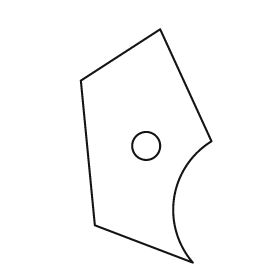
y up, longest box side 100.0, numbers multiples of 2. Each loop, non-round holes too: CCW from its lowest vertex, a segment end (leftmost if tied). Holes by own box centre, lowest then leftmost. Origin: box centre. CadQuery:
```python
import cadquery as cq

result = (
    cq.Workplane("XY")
    .moveTo(20.0, -50.0)
    .threePointArc((12.0, -22.0), (28.0, 2.0))
    .lineTo(6.0, 50.0)
    .lineTo(-28.0, 28.0)
    .lineTo(-22.0, -34.0)
    .close()
    .moveTo(0.0, 0.0)
    .circle(6.0)
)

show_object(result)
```